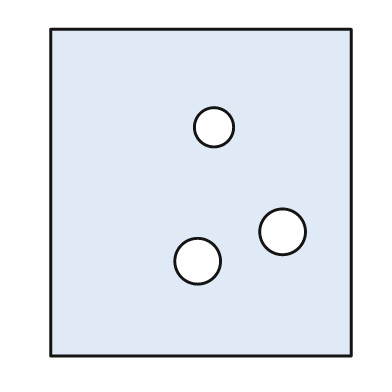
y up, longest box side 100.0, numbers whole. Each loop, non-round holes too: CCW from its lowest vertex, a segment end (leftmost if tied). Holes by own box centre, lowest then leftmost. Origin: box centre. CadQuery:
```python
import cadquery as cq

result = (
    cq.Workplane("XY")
    .moveTo(-46.0, -50.0)
    .lineTo(46.0, -50.0)
    .lineTo(46.0, 50.0)
    .lineTo(-46.0, 50.0)
    .close()
    .moveTo(-1.0, -21.0)
    .circle(7.0)
    .moveTo(25.0, -12.0)
    .circle(7.0)
    .moveTo(4.0, 20.0)
    .circle(6.0)
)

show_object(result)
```